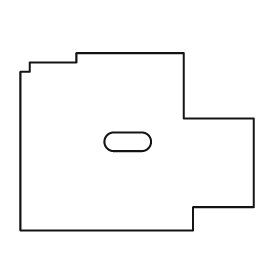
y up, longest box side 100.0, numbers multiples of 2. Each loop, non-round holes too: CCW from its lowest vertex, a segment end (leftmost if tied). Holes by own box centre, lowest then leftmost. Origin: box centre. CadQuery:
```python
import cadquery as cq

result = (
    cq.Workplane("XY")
    .moveTo(-50.0, -38.0)
    .lineTo(24.0, -38.0)
    .lineTo(24.0, -28.0)
    .lineTo(50.0, -28.0)
    .lineTo(50.0, 10.0)
    .lineTo(20.0, 10.0)
    .lineTo(20.0, 38.0)
    .lineTo(-26.0, 38.0)
    .lineTo(-26.0, 34.0)
    .lineTo(-46.0, 34.0)
    .lineTo(-46.0, 30.0)
    .lineTo(-50.0, 30.0)
    .close()
    .moveTo(-10.0, -4.0)
    .lineTo(2.0, -4.0)
    .threePointArc((6.0, 0.0), (2.0, 4.0))
    .lineTo(-10.0, 4.0)
    .threePointArc((-14.0, 0.0), (-10.0, -4.0))
    .close()
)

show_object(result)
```